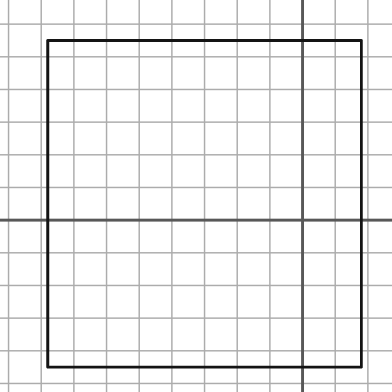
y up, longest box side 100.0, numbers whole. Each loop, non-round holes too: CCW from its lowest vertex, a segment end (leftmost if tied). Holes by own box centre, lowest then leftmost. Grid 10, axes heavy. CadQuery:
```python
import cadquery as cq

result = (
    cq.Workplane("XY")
    .moveTo(-78.0, -45.0)
    .lineTo(18.0, -45.0)
    .lineTo(18.0, 55.0)
    .lineTo(-78.0, 55.0)
    .close()
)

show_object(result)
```